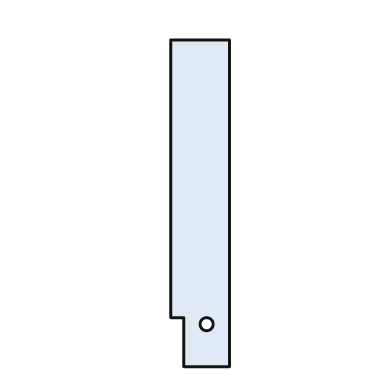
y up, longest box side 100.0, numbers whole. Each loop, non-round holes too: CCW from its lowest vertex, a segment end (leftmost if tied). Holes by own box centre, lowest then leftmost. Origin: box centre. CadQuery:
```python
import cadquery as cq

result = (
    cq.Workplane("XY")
    .moveTo(-5.0, -50.0)
    .lineTo(9.0, -50.0)
    .lineTo(9.0, 50.0)
    .lineTo(-9.0, 50.0)
    .lineTo(-9.0, -35.0)
    .lineTo(-5.0, -35.0)
    .close()
    .moveTo(2.0, -37.0)
    .circle(2.0)
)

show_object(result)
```